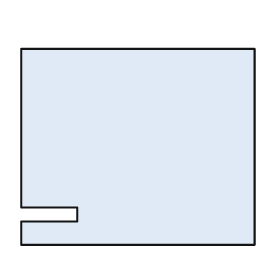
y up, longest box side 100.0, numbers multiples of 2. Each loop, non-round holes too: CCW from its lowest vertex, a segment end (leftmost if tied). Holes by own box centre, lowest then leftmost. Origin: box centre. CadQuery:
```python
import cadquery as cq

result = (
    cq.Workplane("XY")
    .moveTo(-50.0, -42.0)
    .lineTo(50.0, -42.0)
    .lineTo(50.0, 42.0)
    .lineTo(-50.0, 42.0)
    .lineTo(-50.0, -26.0)
    .lineTo(-26.0, -26.0)
    .lineTo(-26.0, -32.0)
    .lineTo(-50.0, -32.0)
    .close()
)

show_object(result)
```